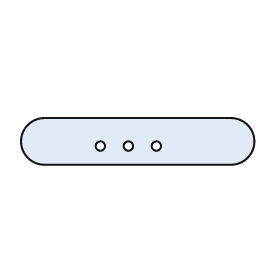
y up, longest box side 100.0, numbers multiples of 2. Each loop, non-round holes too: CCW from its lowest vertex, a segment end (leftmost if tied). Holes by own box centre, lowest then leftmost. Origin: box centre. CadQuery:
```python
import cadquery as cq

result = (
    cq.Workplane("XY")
    .moveTo(-40.0, -10.0)
    .lineTo(40.0, -10.0)
    .threePointArc((50.0, 0.0), (40.0, 10.0))
    .lineTo(-40.0, 10.0)
    .threePointArc((-50.0, 0.0), (-40.0, -10.0))
    .close()
    .moveTo(-16.0, -2.0)
    .circle(2.0)
    .moveTo(-4.0, -2.0)
    .circle(2.0)
    .moveTo(8.0, -2.0)
    .circle(2.0)
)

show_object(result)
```